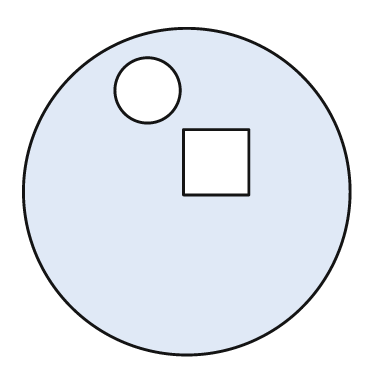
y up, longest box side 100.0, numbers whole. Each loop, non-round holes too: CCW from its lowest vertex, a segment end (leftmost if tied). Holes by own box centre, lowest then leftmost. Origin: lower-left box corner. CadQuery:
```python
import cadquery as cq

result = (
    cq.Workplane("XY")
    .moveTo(50.0, 50.0)
    .circle(50.0)
    .moveTo(49.0, 49.0)
    .lineTo(69.0, 49.0)
    .lineTo(69.0, 69.0)
    .lineTo(49.0, 69.0)
    .close()
    .moveTo(38.0, 81.0)
    .circle(10.0)
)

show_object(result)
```